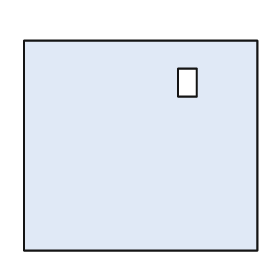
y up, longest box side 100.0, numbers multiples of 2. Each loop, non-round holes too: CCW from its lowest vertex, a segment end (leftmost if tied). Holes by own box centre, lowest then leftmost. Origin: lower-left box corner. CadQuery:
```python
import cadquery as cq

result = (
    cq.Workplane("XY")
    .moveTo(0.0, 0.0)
    .lineTo(100.0, 0.0)
    .lineTo(100.0, 90.0)
    .lineTo(0.0, 90.0)
    .close()
    .moveTo(66.0, 66.0)
    .lineTo(74.0, 66.0)
    .lineTo(74.0, 78.0)
    .lineTo(66.0, 78.0)
    .close()
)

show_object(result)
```